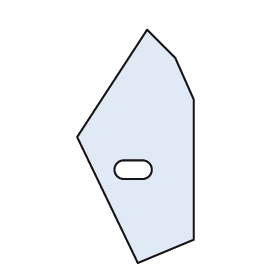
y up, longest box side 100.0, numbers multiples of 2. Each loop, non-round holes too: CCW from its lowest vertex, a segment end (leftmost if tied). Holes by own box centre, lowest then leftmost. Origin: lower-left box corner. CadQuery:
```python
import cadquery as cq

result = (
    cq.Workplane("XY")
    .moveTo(26.0, 0.0)
    .lineTo(50.0, 10.0)
    .lineTo(50.0, 70.0)
    .lineTo(42.0, 88.0)
    .lineTo(30.0, 100.0)
    .lineTo(0.0, 54.0)
    .close()
    .moveTo(20.0, 36.0)
    .lineTo(28.0, 36.0)
    .threePointArc((32.0, 40.0), (28.0, 44.0))
    .lineTo(20.0, 44.0)
    .threePointArc((16.0, 40.0), (20.0, 36.0))
    .close()
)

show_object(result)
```